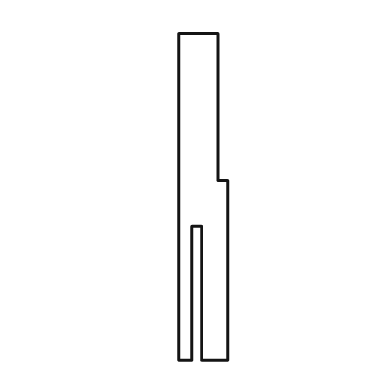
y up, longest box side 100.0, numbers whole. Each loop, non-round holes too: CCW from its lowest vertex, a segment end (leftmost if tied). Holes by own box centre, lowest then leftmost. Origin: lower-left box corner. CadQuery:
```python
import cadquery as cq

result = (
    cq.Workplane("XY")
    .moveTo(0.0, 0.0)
    .lineTo(4.0, 0.0)
    .lineTo(4.0, 41.0)
    .lineTo(7.0, 41.0)
    .lineTo(7.0, 0.0)
    .lineTo(15.0, 0.0)
    .lineTo(15.0, 55.0)
    .lineTo(12.0, 55.0)
    .lineTo(12.0, 100.0)
    .lineTo(0.0, 100.0)
    .close()
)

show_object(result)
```